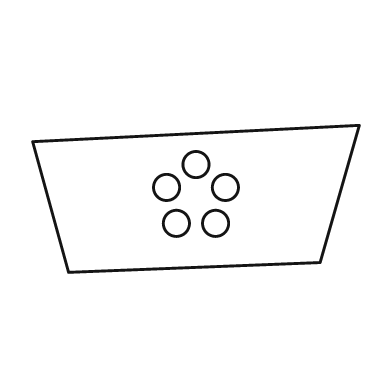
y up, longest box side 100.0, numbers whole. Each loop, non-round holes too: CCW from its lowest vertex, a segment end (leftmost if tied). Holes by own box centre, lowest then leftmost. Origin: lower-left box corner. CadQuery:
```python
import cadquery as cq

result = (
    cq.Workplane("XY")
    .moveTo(11.0, 0.0)
    .lineTo(88.0, 3.0)
    .lineTo(100.0, 45.0)
    .lineTo(0.0, 40.0)
    .close()
    .moveTo(44.0, 15.0)
    .circle(4.0)
    .moveTo(56.0, 15.0)
    .circle(4.0)
    .moveTo(41.0, 26.0)
    .circle(4.0)
    .moveTo(59.0, 26.0)
    .circle(4.0)
    .moveTo(50.0, 33.0)
    .circle(4.0)
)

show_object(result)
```